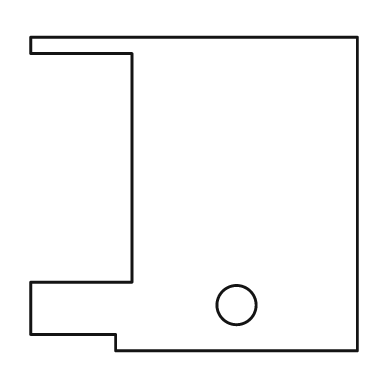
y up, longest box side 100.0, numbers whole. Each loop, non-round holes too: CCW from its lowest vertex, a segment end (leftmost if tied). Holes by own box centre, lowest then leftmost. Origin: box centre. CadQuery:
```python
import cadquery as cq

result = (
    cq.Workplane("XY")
    .moveTo(-24.0, -48.0)
    .lineTo(50.0, -48.0)
    .lineTo(50.0, 48.0)
    .lineTo(-50.0, 48.0)
    .lineTo(-50.0, 43.0)
    .lineTo(-19.0, 43.0)
    .lineTo(-19.0, -27.0)
    .lineTo(-50.0, -27.0)
    .lineTo(-50.0, -43.0)
    .lineTo(-24.0, -43.0)
    .close()
    .moveTo(13.0, -34.0)
    .circle(6.0)
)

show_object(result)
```